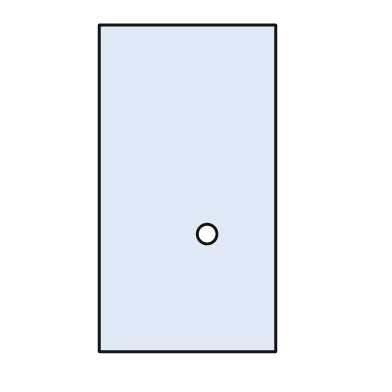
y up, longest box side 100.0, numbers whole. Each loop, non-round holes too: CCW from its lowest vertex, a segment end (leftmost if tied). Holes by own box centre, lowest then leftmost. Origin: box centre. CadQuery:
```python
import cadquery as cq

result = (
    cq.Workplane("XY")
    .moveTo(-27.0, -50.0)
    .lineTo(27.0, -50.0)
    .lineTo(27.0, 50.0)
    .lineTo(-27.0, 50.0)
    .close()
    .moveTo(6.0, -14.0)
    .circle(3.0)
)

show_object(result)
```